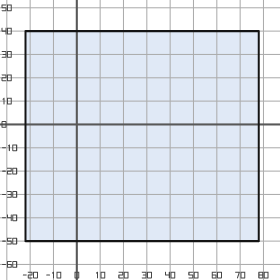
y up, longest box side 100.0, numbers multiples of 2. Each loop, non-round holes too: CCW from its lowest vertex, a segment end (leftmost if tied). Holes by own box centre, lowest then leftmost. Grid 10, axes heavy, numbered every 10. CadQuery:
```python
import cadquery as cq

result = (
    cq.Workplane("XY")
    .moveTo(-22.0, -50.0)
    .lineTo(78.0, -50.0)
    .lineTo(78.0, 40.0)
    .lineTo(-22.0, 40.0)
    .close()
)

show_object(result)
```